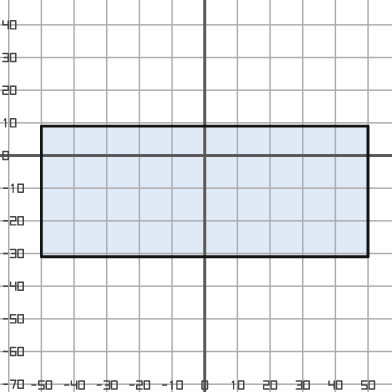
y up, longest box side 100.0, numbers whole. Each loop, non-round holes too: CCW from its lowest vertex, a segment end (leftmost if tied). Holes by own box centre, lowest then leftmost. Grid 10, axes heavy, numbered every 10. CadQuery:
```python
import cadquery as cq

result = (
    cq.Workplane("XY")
    .moveTo(-50.0, -31.0)
    .lineTo(50.0, -31.0)
    .lineTo(50.0, 9.0)
    .lineTo(-50.0, 9.0)
    .close()
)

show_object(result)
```